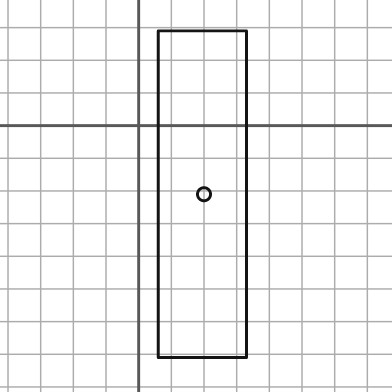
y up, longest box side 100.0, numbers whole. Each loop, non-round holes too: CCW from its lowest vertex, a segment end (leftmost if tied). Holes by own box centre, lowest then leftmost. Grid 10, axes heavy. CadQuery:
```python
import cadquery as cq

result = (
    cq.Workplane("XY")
    .moveTo(6.0, -71.0)
    .lineTo(33.0, -71.0)
    .lineTo(33.0, 29.0)
    .lineTo(6.0, 29.0)
    .close()
    .moveTo(20.0, -21.0)
    .circle(2.0)
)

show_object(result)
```